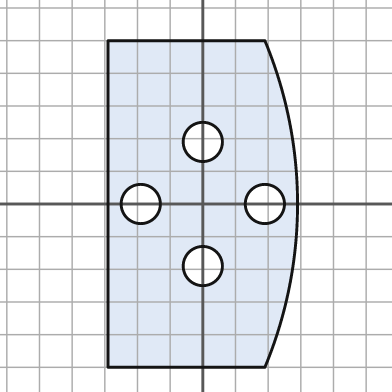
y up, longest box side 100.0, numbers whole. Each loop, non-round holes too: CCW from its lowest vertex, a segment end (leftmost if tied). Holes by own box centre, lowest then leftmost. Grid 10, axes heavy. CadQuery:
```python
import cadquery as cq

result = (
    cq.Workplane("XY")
    .moveTo(-29.0, -50.0)
    .lineTo(19.0, -50.0)
    .threePointArc((29.0, 0.0), (19.0, 50.0))
    .lineTo(-29.0, 50.0)
    .close()
    .moveTo(0.0, -19.0)
    .circle(6.0)
    .moveTo(-19.0, 0.0)
    .circle(6.0)
    .moveTo(19.0, 0.0)
    .circle(6.0)
    .moveTo(0.0, 19.0)
    .circle(6.0)
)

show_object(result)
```